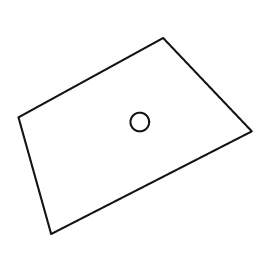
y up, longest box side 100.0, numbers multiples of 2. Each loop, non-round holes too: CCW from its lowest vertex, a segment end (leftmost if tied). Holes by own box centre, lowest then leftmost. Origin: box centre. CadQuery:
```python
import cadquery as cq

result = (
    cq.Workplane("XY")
    .moveTo(-36.0, -42.0)
    .lineTo(50.0, 2.0)
    .lineTo(12.0, 42.0)
    .lineTo(-50.0, 8.0)
    .close()
    .moveTo(2.0, 6.0)
    .circle(4.0)
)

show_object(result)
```